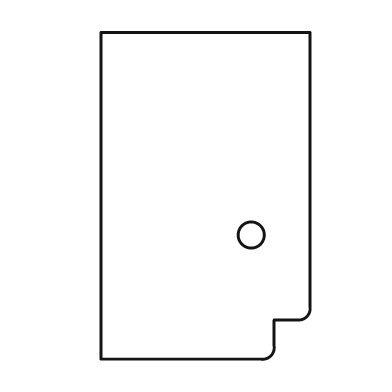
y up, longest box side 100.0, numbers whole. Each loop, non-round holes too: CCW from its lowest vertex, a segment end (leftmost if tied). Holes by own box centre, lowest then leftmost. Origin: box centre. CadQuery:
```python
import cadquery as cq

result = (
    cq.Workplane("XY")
    .moveTo(-32.0, -50.0)
    .lineTo(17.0, -50.0)
    .threePointArc((20.0, -49.0), (21.0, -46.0))
    .lineTo(21.0, -38.0)
    .lineTo(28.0, -38.0)
    .threePointArc((31.0, -37.0), (32.0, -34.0))
    .lineTo(32.0, 50.0)
    .lineTo(-32.0, 50.0)
    .close()
    .moveTo(14.0, -12.0)
    .circle(4.0)
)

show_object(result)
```